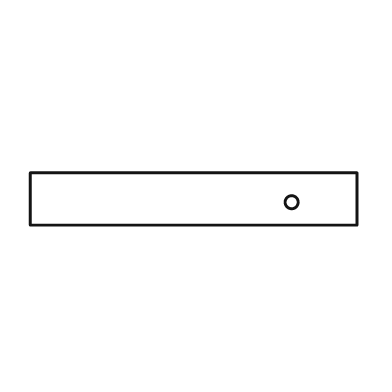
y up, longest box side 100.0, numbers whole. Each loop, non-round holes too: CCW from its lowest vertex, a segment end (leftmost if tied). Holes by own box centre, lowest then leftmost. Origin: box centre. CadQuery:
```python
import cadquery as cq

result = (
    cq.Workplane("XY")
    .moveTo(-50.0, -8.0)
    .lineTo(50.0, -8.0)
    .lineTo(50.0, 8.0)
    .lineTo(-50.0, 8.0)
    .close()
    .moveTo(30.0, -1.0)
    .circle(2.0)
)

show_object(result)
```